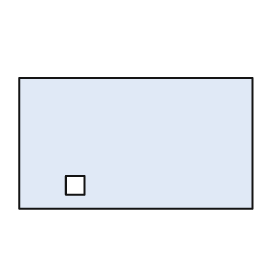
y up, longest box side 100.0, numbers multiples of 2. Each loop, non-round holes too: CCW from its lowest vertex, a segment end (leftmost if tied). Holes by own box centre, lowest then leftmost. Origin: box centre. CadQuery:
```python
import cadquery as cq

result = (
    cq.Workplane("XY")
    .moveTo(-50.0, -28.0)
    .lineTo(50.0, -28.0)
    .lineTo(50.0, 28.0)
    .lineTo(-50.0, 28.0)
    .close()
    .moveTo(-30.0, -22.0)
    .lineTo(-22.0, -22.0)
    .lineTo(-22.0, -14.0)
    .lineTo(-30.0, -14.0)
    .close()
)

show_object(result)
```